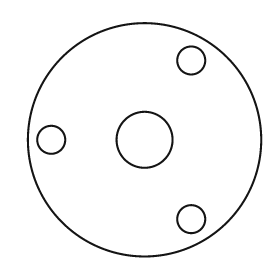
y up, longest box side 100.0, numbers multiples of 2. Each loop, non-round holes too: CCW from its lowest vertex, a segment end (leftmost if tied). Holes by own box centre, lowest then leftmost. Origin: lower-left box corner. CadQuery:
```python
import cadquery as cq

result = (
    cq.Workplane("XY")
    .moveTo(50.0, 50.0)
    .circle(50.0)
    .moveTo(70.0, 16.0)
    .circle(6.0)
    .moveTo(10.0, 50.0)
    .circle(6.0)
    .moveTo(50.0, 50.0)
    .circle(12.0)
    .moveTo(70.0, 84.0)
    .circle(6.0)
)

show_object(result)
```